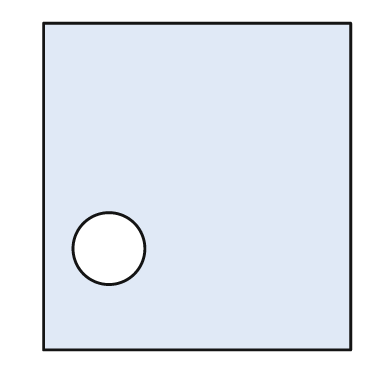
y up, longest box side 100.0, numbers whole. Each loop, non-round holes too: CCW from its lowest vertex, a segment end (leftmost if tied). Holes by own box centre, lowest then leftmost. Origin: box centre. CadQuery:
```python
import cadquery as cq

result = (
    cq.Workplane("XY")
    .moveTo(-47.0, -50.0)
    .lineTo(47.0, -50.0)
    .lineTo(47.0, 50.0)
    .lineTo(-47.0, 50.0)
    .close()
    .moveTo(-27.0, -19.0)
    .circle(11.0)
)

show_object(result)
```